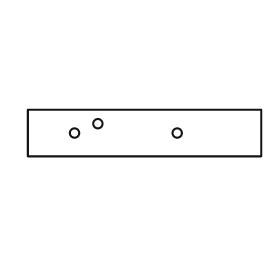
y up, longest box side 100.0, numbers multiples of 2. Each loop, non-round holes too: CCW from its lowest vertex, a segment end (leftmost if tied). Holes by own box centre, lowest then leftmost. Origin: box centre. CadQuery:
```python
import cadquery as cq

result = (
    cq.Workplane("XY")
    .moveTo(-50.0, -10.0)
    .lineTo(50.0, -10.0)
    .lineTo(50.0, 10.0)
    .lineTo(-50.0, 10.0)
    .close()
    .moveTo(-30.0, 0.0)
    .circle(2.0)
    .moveTo(14.0, 0.0)
    .circle(2.0)
    .moveTo(-20.0, 4.0)
    .circle(2.0)
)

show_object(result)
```